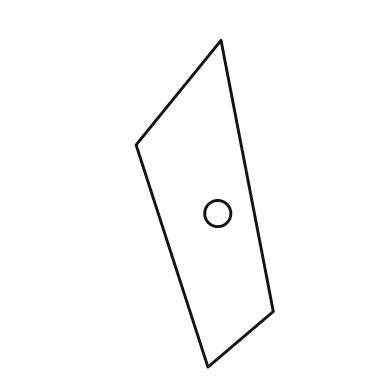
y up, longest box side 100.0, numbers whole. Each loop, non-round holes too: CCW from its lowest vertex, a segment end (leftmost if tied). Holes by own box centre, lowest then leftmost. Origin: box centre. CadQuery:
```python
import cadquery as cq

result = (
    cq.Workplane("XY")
    .moveTo(1.0, -50.0)
    .lineTo(21.0, -33.0)
    .lineTo(5.0, 50.0)
    .lineTo(-21.0, 18.0)
    .close()
    .moveTo(4.0, -3.0)
    .circle(4.0)
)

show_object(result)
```